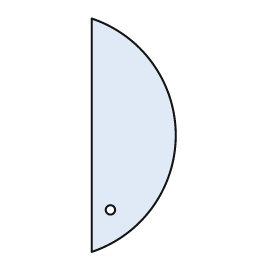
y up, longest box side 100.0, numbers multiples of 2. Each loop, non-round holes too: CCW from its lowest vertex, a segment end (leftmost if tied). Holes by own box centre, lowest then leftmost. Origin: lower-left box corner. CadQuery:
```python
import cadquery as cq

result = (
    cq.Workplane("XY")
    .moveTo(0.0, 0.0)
    .threePointArc((36.0, 50.0), (0.0, 100.0))
    .close()
    .moveTo(8.0, 18.0)
    .circle(2.0)
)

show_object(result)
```